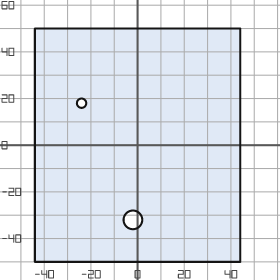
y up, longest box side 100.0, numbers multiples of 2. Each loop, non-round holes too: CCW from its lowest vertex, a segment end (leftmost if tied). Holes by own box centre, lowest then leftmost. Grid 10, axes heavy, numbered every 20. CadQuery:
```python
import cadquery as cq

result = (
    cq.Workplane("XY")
    .moveTo(-44.0, -50.0)
    .lineTo(44.0, -50.0)
    .lineTo(44.0, 50.0)
    .lineTo(-44.0, 50.0)
    .close()
    .moveTo(-2.0, -32.0)
    .circle(4.0)
    .moveTo(-24.0, 18.0)
    .circle(2.0)
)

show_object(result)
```